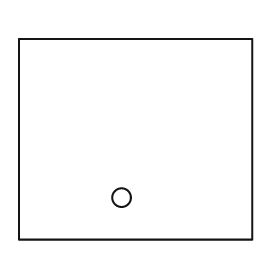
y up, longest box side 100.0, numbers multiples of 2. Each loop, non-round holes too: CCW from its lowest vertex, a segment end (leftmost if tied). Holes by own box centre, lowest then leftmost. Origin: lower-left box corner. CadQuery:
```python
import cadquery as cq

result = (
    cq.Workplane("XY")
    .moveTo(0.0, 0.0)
    .lineTo(100.0, 0.0)
    .lineTo(100.0, 86.0)
    .lineTo(0.0, 86.0)
    .close()
    .moveTo(44.0, 18.0)
    .circle(4.0)
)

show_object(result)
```